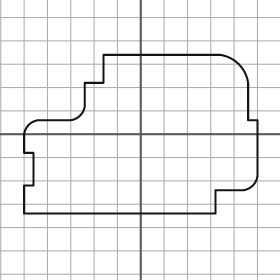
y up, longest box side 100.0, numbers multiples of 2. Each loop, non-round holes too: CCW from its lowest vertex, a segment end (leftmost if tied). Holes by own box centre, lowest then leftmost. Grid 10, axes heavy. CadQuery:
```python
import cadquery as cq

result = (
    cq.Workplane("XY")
    .moveTo(-50.0, -34.0)
    .lineTo(32.0, -34.0)
    .lineTo(32.0, -24.0)
    .lineTo(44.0, -24.0)
    .threePointArc((48.0, -22.0), (50.0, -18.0))
    .lineTo(50.0, 6.0)
    .lineTo(46.0, 6.0)
    .lineTo(46.0, 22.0)
    .threePointArc((42.0, 30.0), (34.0, 34.0))
    .lineTo(-16.0, 34.0)
    .lineTo(-16.0, 22.0)
    .lineTo(-24.0, 22.0)
    .lineTo(-24.0, 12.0)
    .threePointArc((-26.0, 8.0), (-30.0, 6.0))
    .lineTo(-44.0, 6.0)
    .threePointArc((-48.0, 4.0), (-50.0, 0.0))
    .lineTo(-50.0, -8.0)
    .lineTo(-46.0, -8.0)
    .lineTo(-46.0, -22.0)
    .lineTo(-50.0, -22.0)
    .close()
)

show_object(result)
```